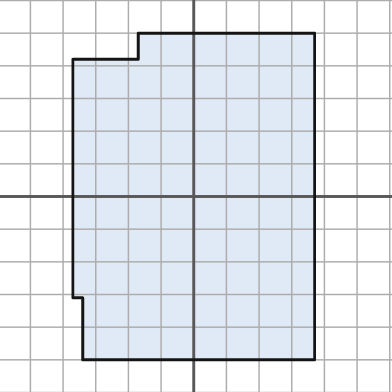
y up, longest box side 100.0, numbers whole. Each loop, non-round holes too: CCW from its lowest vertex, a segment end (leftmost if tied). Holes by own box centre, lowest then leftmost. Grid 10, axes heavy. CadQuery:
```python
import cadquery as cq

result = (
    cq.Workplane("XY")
    .moveTo(-34.0, -50.0)
    .lineTo(37.0, -50.0)
    .lineTo(37.0, 50.0)
    .lineTo(-17.0, 50.0)
    .lineTo(-17.0, 42.0)
    .lineTo(-37.0, 42.0)
    .lineTo(-37.0, -31.0)
    .lineTo(-34.0, -31.0)
    .close()
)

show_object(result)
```